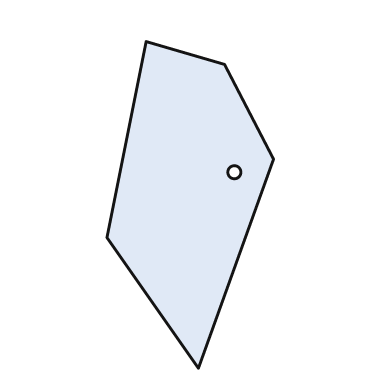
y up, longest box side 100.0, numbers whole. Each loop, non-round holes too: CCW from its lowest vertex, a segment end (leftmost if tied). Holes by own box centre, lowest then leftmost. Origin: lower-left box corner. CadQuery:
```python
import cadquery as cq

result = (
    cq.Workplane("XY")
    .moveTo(28.0, 0.0)
    .lineTo(51.0, 64.0)
    .lineTo(36.0, 93.0)
    .lineTo(12.0, 100.0)
    .lineTo(0.0, 40.0)
    .close()
    .moveTo(39.0, 60.0)
    .circle(2.0)
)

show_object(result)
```